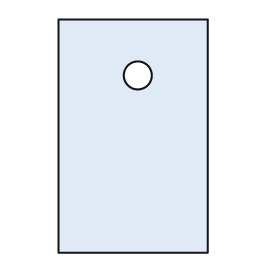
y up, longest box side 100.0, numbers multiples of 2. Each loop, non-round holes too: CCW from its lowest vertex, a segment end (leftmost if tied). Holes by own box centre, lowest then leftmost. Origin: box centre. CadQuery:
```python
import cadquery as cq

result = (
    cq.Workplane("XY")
    .moveTo(-32.0, -50.0)
    .lineTo(32.0, -50.0)
    .lineTo(32.0, 50.0)
    .lineTo(-32.0, 50.0)
    .close()
    .moveTo(2.0, 26.0)
    .circle(6.0)
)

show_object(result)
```